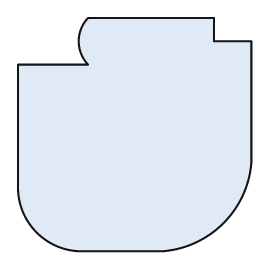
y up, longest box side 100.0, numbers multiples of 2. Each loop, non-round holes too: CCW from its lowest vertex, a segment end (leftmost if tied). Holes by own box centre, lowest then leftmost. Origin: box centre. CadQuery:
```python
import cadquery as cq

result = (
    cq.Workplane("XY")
    .moveTo(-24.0, -50.0)
    .lineTo(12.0, -50.0)
    .threePointArc((38.0, -38.0), (50.0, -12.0))
    .lineTo(50.0, 40.0)
    .lineTo(34.0, 40.0)
    .lineTo(34.0, 50.0)
    .lineTo(-20.0, 50.0)
    .threePointArc((-24.0, 40.0), (-20.0, 30.0))
    .lineTo(-50.0, 30.0)
    .lineTo(-50.0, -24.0)
    .threePointArc((-42.0, -42.0), (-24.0, -50.0))
    .close()
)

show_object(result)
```